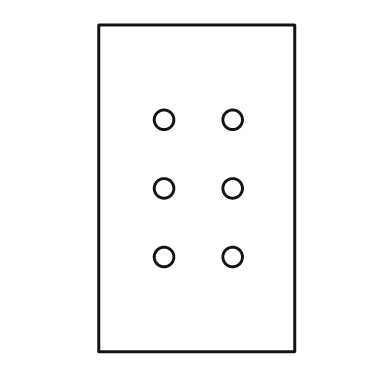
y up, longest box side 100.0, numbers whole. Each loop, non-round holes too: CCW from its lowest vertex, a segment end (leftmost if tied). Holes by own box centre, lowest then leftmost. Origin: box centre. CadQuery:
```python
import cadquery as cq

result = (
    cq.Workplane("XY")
    .moveTo(-30.0, -50.0)
    .lineTo(30.0, -50.0)
    .lineTo(30.0, 50.0)
    .lineTo(-30.0, 50.0)
    .close()
    .moveTo(-10.0, -21.0)
    .circle(3.0)
    .moveTo(11.0, -21.0)
    .circle(3.0)
    .moveTo(-10.0, 0.0)
    .circle(3.0)
    .moveTo(11.0, 0.0)
    .circle(3.0)
    .moveTo(-10.0, 21.0)
    .circle(3.0)
    .moveTo(11.0, 21.0)
    .circle(3.0)
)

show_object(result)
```